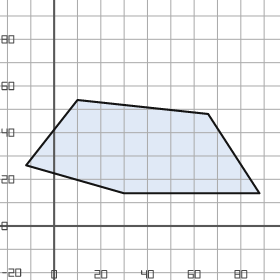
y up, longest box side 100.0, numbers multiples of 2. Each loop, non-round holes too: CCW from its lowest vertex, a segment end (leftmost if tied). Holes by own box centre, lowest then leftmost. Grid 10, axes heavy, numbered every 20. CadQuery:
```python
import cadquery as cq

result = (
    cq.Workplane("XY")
    .moveTo(30.0, 14.0)
    .lineTo(88.0, 14.0)
    .lineTo(66.0, 48.0)
    .lineTo(10.0, 54.0)
    .lineTo(-12.0, 26.0)
    .close()
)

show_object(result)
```